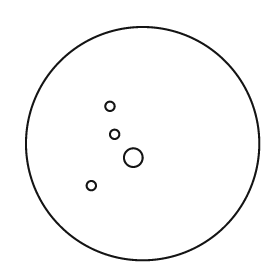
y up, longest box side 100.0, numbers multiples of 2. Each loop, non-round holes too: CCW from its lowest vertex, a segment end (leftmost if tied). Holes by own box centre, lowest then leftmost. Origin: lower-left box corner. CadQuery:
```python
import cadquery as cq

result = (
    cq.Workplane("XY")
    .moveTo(50.0, 50.0)
    .circle(50.0)
    .moveTo(28.0, 32.0)
    .circle(2.0)
    .moveTo(46.0, 44.0)
    .circle(4.0)
    .moveTo(38.0, 54.0)
    .circle(2.0)
    .moveTo(36.0, 66.0)
    .circle(2.0)
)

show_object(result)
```